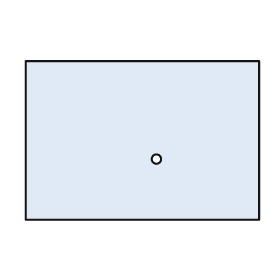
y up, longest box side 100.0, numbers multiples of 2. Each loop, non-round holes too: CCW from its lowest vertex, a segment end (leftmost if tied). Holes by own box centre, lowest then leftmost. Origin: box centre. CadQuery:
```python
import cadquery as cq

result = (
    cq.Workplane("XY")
    .moveTo(-50.0, -34.0)
    .lineTo(50.0, -34.0)
    .lineTo(50.0, 34.0)
    .lineTo(-50.0, 34.0)
    .close()
    .moveTo(6.0, -8.0)
    .circle(2.0)
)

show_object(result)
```